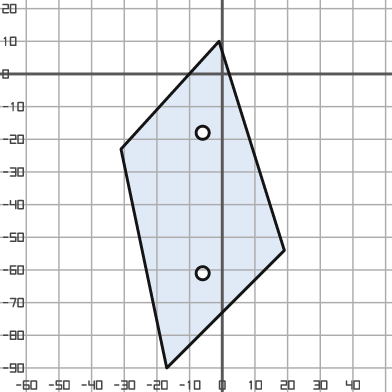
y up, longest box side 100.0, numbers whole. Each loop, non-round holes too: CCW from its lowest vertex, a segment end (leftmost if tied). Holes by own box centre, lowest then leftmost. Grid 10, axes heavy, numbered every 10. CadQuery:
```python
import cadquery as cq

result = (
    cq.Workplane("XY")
    .moveTo(-17.0, -90.0)
    .lineTo(19.0, -54.0)
    .lineTo(-1.0, 10.0)
    .lineTo(-31.0, -23.0)
    .close()
    .moveTo(-6.0, -61.0)
    .circle(2.0)
    .moveTo(-6.0, -18.0)
    .circle(2.0)
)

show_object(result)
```